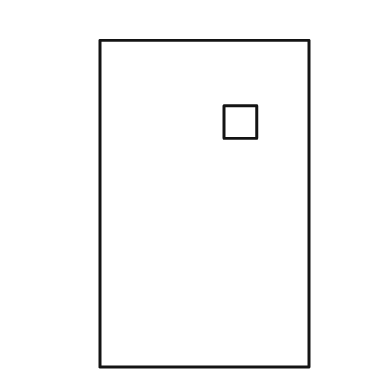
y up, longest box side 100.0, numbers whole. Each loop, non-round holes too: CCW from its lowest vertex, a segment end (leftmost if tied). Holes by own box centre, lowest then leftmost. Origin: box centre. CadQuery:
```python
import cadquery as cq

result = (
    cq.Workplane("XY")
    .moveTo(-32.0, -50.0)
    .lineTo(32.0, -50.0)
    .lineTo(32.0, 50.0)
    .lineTo(-32.0, 50.0)
    .close()
    .moveTo(6.0, 20.0)
    .lineTo(16.0, 20.0)
    .lineTo(16.0, 30.0)
    .lineTo(6.0, 30.0)
    .close()
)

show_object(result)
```